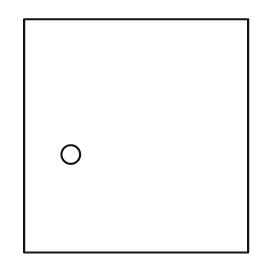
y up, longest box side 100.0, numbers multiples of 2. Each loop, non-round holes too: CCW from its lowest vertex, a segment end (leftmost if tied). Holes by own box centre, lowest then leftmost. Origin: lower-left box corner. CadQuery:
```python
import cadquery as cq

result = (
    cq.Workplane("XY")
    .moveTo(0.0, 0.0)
    .lineTo(96.0, 0.0)
    .lineTo(96.0, 100.0)
    .lineTo(0.0, 100.0)
    .close()
    .moveTo(20.0, 42.0)
    .circle(4.0)
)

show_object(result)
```